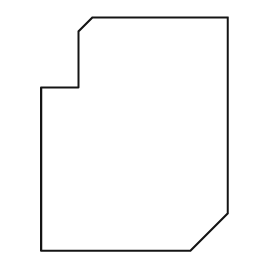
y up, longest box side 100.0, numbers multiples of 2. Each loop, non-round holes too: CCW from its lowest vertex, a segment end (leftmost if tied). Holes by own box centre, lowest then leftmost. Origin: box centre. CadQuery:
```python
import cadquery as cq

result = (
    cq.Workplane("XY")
    .moveTo(-40.0, -50.0)
    .lineTo(24.0, -50.0)
    .lineTo(40.0, -34.0)
    .lineTo(40.0, 50.0)
    .lineTo(-18.0, 50.0)
    .lineTo(-24.0, 44.0)
    .lineTo(-24.0, 20.0)
    .lineTo(-40.0, 20.0)
    .close()
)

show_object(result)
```